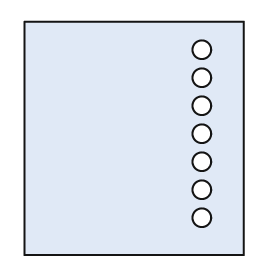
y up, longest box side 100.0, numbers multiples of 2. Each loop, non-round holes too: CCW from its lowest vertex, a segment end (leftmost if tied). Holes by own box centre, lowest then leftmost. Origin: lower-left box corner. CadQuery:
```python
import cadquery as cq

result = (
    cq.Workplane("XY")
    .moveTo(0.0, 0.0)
    .lineTo(94.0, 0.0)
    .lineTo(94.0, 100.0)
    .lineTo(0.0, 100.0)
    .close()
    .moveTo(76.0, 16.0)
    .circle(4.0)
    .moveTo(76.0, 28.0)
    .circle(4.0)
    .moveTo(76.0, 40.0)
    .circle(4.0)
    .moveTo(76.0, 52.0)
    .circle(4.0)
    .moveTo(76.0, 64.0)
    .circle(4.0)
    .moveTo(76.0, 76.0)
    .circle(4.0)
    .moveTo(76.0, 88.0)
    .circle(4.0)
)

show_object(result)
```